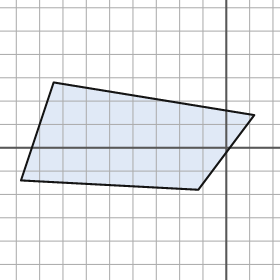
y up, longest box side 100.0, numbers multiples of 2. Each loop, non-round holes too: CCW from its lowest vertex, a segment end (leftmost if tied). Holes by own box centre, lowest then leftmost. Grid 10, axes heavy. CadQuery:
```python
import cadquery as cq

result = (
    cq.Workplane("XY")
    .moveTo(-12.0, -18.0)
    .lineTo(12.0, 14.0)
    .lineTo(-74.0, 28.0)
    .lineTo(-88.0, -14.0)
    .close()
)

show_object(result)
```